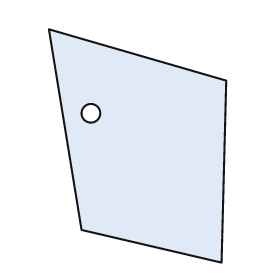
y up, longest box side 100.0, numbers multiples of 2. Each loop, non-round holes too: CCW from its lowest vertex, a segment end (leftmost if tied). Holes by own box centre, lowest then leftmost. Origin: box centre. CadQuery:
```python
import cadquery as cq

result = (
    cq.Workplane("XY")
    .moveTo(36.0, -50.0)
    .lineTo(38.0, 28.0)
    .lineTo(-38.0, 50.0)
    .lineTo(-24.0, -36.0)
    .close()
    .moveTo(-20.0, 14.0)
    .circle(4.0)
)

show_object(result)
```